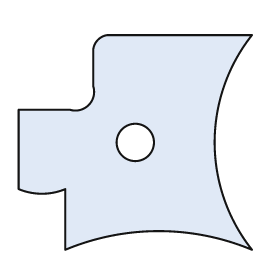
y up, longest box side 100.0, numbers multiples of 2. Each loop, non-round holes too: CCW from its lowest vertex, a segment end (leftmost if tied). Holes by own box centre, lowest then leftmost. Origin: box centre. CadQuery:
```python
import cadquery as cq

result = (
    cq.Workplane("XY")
    .moveTo(-30.0, -46.0)
    .threePointArc((10.0, -38.0), (50.0, -46.0))
    .threePointArc((34.0, 0.0), (50.0, 46.0))
    .lineTo(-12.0, 46.0)
    .threePointArc((-16.0, 44.0), (-18.0, 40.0))
    .lineTo(-18.0, 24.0)
    .threePointArc((-20.0, 16.0), (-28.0, 14.0))
    .lineTo(-50.0, 14.0)
    .lineTo(-50.0, -20.0)
    .threePointArc((-40.0, -22.0), (-30.0, -20.0))
    .close()
    .moveTo(0.0, 0.0)
    .circle(8.0)
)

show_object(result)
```